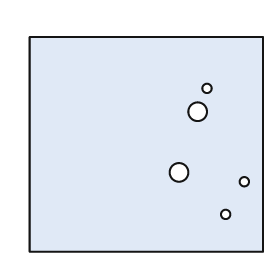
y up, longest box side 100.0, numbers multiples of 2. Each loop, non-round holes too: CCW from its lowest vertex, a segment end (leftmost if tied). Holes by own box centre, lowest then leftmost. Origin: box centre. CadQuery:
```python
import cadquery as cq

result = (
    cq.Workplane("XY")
    .moveTo(-50.0, -46.0)
    .lineTo(50.0, -46.0)
    .lineTo(50.0, 46.0)
    .lineTo(-50.0, 46.0)
    .close()
    .moveTo(34.0, -30.0)
    .circle(2.0)
    .moveTo(42.0, -16.0)
    .circle(2.0)
    .moveTo(14.0, -12.0)
    .circle(4.0)
    .moveTo(22.0, 14.0)
    .circle(4.0)
    .moveTo(26.0, 24.0)
    .circle(2.0)
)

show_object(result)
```